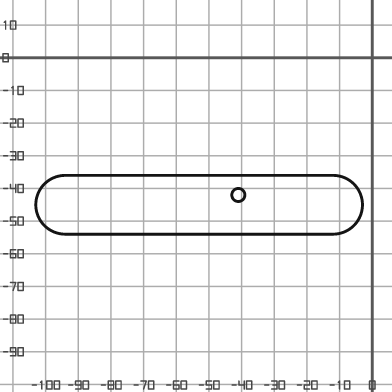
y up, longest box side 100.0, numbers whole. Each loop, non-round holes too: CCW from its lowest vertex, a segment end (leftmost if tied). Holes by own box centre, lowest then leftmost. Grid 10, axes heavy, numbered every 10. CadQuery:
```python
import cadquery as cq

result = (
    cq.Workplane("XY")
    .moveTo(-94.0, -54.0)
    .lineTo(-12.0, -54.0)
    .threePointArc((-3.0, -45.0), (-12.0, -36.0))
    .lineTo(-94.0, -36.0)
    .threePointArc((-103.0, -45.0), (-94.0, -54.0))
    .close()
    .moveTo(-41.0, -42.0)
    .circle(2.0)
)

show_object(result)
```